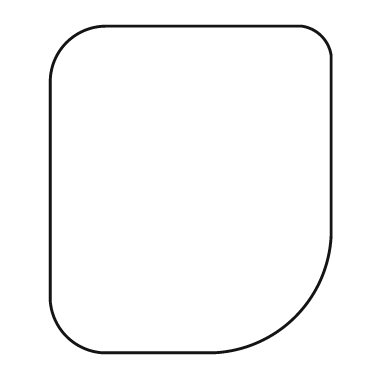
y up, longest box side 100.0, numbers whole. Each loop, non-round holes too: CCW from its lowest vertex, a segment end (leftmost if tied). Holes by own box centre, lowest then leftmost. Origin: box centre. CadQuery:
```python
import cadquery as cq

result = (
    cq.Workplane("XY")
    .moveTo(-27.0, -50.0)
    .lineTo(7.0, -50.0)
    .threePointArc((32.0, -39.0), (43.0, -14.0))
    .lineTo(43.0, 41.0)
    .threePointArc((40.0, 47.0), (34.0, 50.0))
    .lineTo(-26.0, 50.0)
    .threePointArc((-38.0, 45.0), (-43.0, 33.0))
    .lineTo(-43.0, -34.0)
    .threePointArc((-38.0, -45.0), (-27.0, -50.0))
    .close()
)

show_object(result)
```